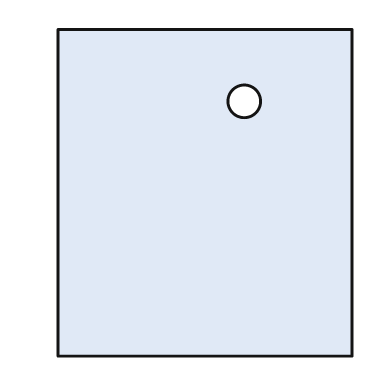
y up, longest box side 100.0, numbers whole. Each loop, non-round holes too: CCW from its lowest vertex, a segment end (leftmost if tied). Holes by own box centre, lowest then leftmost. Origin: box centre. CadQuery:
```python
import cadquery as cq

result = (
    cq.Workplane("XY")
    .moveTo(-45.0, -50.0)
    .lineTo(45.0, -50.0)
    .lineTo(45.0, 50.0)
    .lineTo(-45.0, 50.0)
    .close()
    .moveTo(12.0, 28.0)
    .circle(5.0)
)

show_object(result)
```